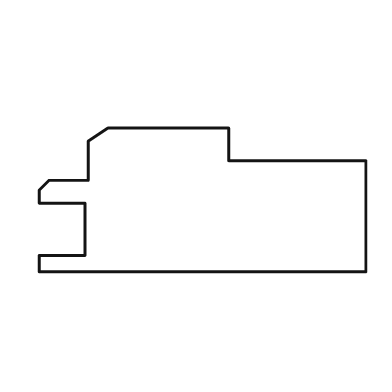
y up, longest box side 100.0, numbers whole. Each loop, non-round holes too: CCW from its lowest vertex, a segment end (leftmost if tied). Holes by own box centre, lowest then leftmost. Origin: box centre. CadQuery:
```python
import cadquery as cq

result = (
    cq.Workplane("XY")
    .moveTo(-50.0, -22.0)
    .lineTo(50.0, -22.0)
    .lineTo(50.0, 12.0)
    .lineTo(8.0, 12.0)
    .lineTo(8.0, 22.0)
    .lineTo(-29.0, 22.0)
    .lineTo(-35.0, 18.0)
    .lineTo(-35.0, 6.0)
    .lineTo(-47.0, 6.0)
    .lineTo(-50.0, 3.0)
    .lineTo(-50.0, -1.0)
    .lineTo(-36.0, -1.0)
    .lineTo(-36.0, -17.0)
    .lineTo(-50.0, -17.0)
    .close()
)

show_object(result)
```